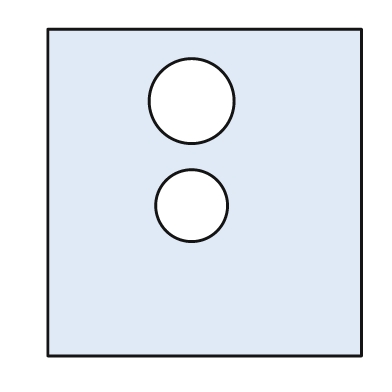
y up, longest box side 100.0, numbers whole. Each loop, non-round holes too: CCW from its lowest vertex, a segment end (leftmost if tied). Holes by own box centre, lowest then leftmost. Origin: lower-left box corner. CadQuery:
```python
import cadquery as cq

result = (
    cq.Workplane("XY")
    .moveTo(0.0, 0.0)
    .lineTo(96.0, 0.0)
    .lineTo(96.0, 100.0)
    .lineTo(0.0, 100.0)
    .close()
    .moveTo(44.0, 46.0)
    .circle(11.0)
    .moveTo(44.0, 78.0)
    .circle(13.0)
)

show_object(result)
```